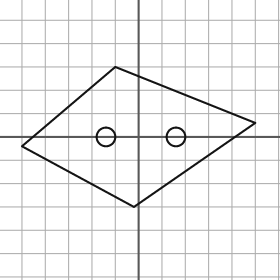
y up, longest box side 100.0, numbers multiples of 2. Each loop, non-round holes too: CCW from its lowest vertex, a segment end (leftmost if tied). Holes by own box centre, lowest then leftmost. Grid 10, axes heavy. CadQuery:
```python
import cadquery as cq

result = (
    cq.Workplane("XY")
    .moveTo(-2.0, -30.0)
    .lineTo(50.0, 6.0)
    .lineTo(-10.0, 30.0)
    .lineTo(-50.0, -4.0)
    .close()
    .moveTo(-14.0, 0.0)
    .circle(4.0)
    .moveTo(16.0, 0.0)
    .circle(4.0)
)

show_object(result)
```